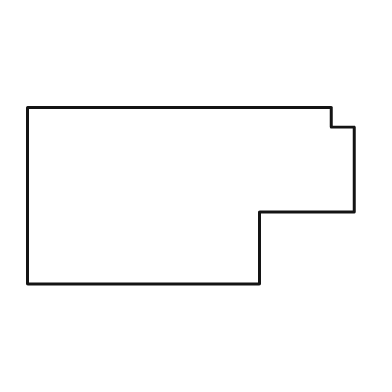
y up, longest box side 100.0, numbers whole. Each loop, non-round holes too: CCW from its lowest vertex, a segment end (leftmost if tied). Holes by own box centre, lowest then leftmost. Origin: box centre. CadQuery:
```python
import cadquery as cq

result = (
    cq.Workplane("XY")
    .moveTo(-50.0, -27.0)
    .lineTo(21.0, -27.0)
    .lineTo(21.0, -5.0)
    .lineTo(50.0, -5.0)
    .lineTo(50.0, 21.0)
    .lineTo(43.0, 21.0)
    .lineTo(43.0, 27.0)
    .lineTo(-50.0, 27.0)
    .close()
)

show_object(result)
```